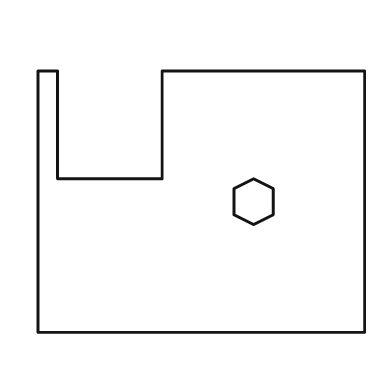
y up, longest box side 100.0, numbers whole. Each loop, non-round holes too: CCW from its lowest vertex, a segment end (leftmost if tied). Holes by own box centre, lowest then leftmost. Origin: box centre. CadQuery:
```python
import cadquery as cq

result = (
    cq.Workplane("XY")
    .moveTo(-50.0, -40.0)
    .lineTo(50.0, -40.0)
    .lineTo(50.0, 40.0)
    .lineTo(-12.0, 40.0)
    .lineTo(-12.0, 7.0)
    .lineTo(-44.0, 7.0)
    .lineTo(-44.0, 40.0)
    .lineTo(-50.0, 40.0)
    .close()
    .moveTo(16.0, -7.0)
    .lineTo(22.0, -4.0)
    .lineTo(22.0, 4.0)
    .lineTo(16.0, 7.0)
    .lineTo(10.0, 4.0)
    .lineTo(10.0, -4.0)
    .close()
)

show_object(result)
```